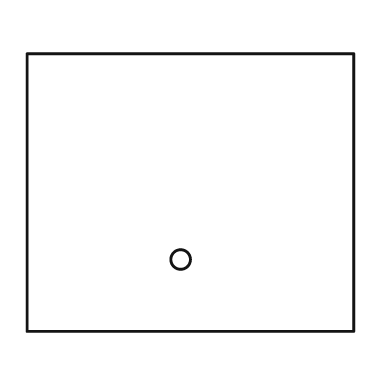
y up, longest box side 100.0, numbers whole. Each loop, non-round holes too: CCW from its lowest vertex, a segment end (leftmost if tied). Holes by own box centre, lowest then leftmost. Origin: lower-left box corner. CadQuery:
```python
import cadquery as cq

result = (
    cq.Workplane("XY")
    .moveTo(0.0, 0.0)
    .lineTo(100.0, 0.0)
    .lineTo(100.0, 85.0)
    .lineTo(0.0, 85.0)
    .close()
    .moveTo(47.0, 22.0)
    .circle(3.0)
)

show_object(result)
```